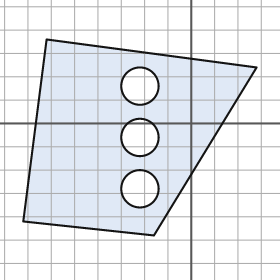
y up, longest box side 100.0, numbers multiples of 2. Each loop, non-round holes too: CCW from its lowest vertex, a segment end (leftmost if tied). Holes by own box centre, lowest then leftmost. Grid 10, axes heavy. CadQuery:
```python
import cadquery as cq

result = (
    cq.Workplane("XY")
    .moveTo(-16.0, -48.0)
    .lineTo(28.0, 24.0)
    .lineTo(-62.0, 36.0)
    .lineTo(-72.0, -42.0)
    .close()
    .moveTo(-22.0, -28.0)
    .circle(8.0)
    .moveTo(-22.0, -6.0)
    .circle(8.0)
    .moveTo(-22.0, 16.0)
    .circle(8.0)
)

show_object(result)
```